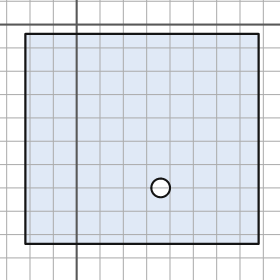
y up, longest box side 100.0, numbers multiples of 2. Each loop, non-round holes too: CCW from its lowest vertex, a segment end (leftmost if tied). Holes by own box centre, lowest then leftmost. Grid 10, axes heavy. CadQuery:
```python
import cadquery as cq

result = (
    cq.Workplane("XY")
    .moveTo(-22.0, -94.0)
    .lineTo(78.0, -94.0)
    .lineTo(78.0, -4.0)
    .lineTo(-22.0, -4.0)
    .close()
    .moveTo(36.0, -70.0)
    .circle(4.0)
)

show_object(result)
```